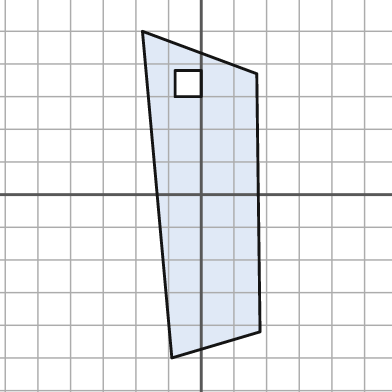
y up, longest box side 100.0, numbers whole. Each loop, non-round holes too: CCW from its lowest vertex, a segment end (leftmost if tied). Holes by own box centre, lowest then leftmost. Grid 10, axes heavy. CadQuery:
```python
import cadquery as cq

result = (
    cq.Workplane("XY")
    .moveTo(-9.0, -50.0)
    .lineTo(18.0, -42.0)
    .lineTo(17.0, 37.0)
    .lineTo(-18.0, 50.0)
    .close()
    .moveTo(-8.0, 30.0)
    .lineTo(0.0, 30.0)
    .lineTo(0.0, 38.0)
    .lineTo(-8.0, 38.0)
    .close()
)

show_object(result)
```